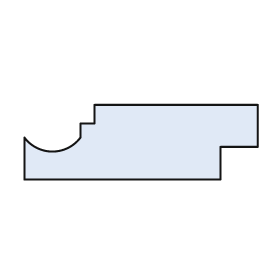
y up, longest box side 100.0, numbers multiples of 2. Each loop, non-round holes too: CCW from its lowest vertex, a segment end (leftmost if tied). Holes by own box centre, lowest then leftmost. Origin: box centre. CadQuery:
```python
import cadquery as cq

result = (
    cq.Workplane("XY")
    .moveTo(-50.0, -16.0)
    .lineTo(34.0, -16.0)
    .lineTo(34.0, -2.0)
    .lineTo(50.0, -2.0)
    .lineTo(50.0, 16.0)
    .lineTo(-20.0, 16.0)
    .lineTo(-20.0, 8.0)
    .lineTo(-26.0, 8.0)
    .lineTo(-26.0, 2.0)
    .threePointArc((-38.0, -4.0), (-50.0, 2.0))
    .close()
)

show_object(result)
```